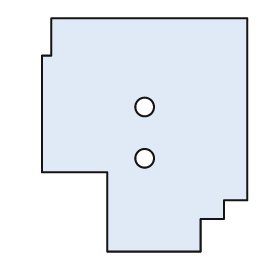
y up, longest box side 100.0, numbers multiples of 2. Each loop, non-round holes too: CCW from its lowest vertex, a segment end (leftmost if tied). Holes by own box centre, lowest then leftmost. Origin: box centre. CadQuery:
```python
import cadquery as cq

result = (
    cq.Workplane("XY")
    .moveTo(-16.0, -50.0)
    .lineTo(24.0, -50.0)
    .lineTo(24.0, -36.0)
    .lineTo(34.0, -36.0)
    .lineTo(34.0, -28.0)
    .lineTo(44.0, -28.0)
    .lineTo(44.0, 50.0)
    .lineTo(-40.0, 50.0)
    .lineTo(-40.0, 34.0)
    .lineTo(-44.0, 34.0)
    .lineTo(-44.0, -16.0)
    .lineTo(-16.0, -16.0)
    .close()
    .moveTo(0.0, -10.0)
    .circle(4.0)
    .moveTo(0.0, 12.0)
    .circle(4.0)
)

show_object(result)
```